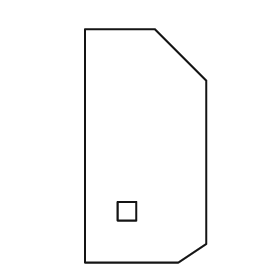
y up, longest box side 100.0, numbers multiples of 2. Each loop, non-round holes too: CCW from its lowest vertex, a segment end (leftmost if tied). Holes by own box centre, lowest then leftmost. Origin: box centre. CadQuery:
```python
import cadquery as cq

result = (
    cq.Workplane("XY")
    .moveTo(-26.0, -50.0)
    .lineTo(14.0, -50.0)
    .lineTo(26.0, -42.0)
    .lineTo(26.0, 28.0)
    .lineTo(4.0, 50.0)
    .lineTo(-26.0, 50.0)
    .close()
    .moveTo(-12.0, -32.0)
    .lineTo(-4.0, -32.0)
    .lineTo(-4.0, -24.0)
    .lineTo(-12.0, -24.0)
    .close()
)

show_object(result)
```